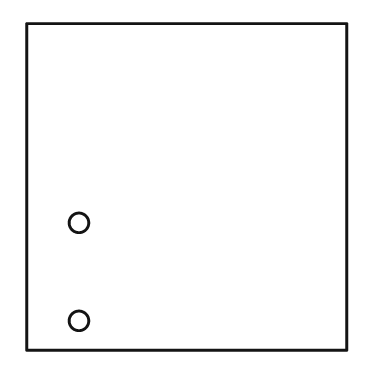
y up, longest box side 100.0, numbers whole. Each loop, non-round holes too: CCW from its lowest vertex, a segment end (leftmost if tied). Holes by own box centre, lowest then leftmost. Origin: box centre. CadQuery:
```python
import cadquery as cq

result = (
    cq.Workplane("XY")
    .moveTo(-49.0, -50.0)
    .lineTo(49.0, -50.0)
    .lineTo(49.0, 50.0)
    .lineTo(-49.0, 50.0)
    .close()
    .moveTo(-33.0, -41.0)
    .circle(3.0)
    .moveTo(-33.0, -11.0)
    .circle(3.0)
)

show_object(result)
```